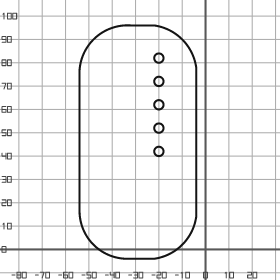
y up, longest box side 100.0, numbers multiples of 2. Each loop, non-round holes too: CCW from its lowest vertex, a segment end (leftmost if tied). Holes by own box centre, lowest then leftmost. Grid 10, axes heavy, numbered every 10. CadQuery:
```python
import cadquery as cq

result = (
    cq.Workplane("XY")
    .moveTo(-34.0, -4.0)
    .lineTo(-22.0, -4.0)
    .threePointArc((-10.0, 2.0), (-4.0, 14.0))
    .lineTo(-4.0, 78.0)
    .threePointArc((-10.0, 90.0), (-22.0, 96.0))
    .lineTo(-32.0, 96.0)
    .threePointArc((-48.0, 90.0), (-54.0, 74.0))
    .lineTo(-54.0, 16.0)
    .threePointArc((-48.0, 2.0), (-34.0, -4.0))
    .close()
    .moveTo(-20.0, 42.0)
    .circle(2.0)
    .moveTo(-20.0, 52.0)
    .circle(2.0)
    .moveTo(-20.0, 62.0)
    .circle(2.0)
    .moveTo(-20.0, 72.0)
    .circle(2.0)
    .moveTo(-20.0, 82.0)
    .circle(2.0)
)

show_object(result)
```